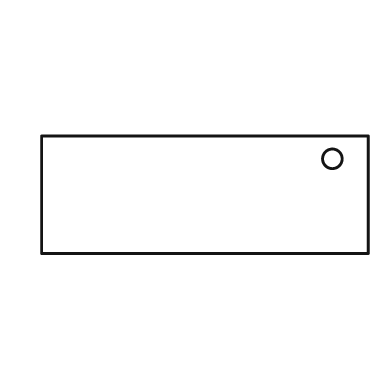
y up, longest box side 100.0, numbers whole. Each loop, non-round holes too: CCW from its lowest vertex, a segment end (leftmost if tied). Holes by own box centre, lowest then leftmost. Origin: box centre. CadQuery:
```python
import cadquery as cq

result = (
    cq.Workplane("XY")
    .moveTo(-50.0, -18.0)
    .lineTo(50.0, -18.0)
    .lineTo(50.0, 18.0)
    .lineTo(-50.0, 18.0)
    .close()
    .moveTo(39.0, 11.0)
    .circle(3.0)
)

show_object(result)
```